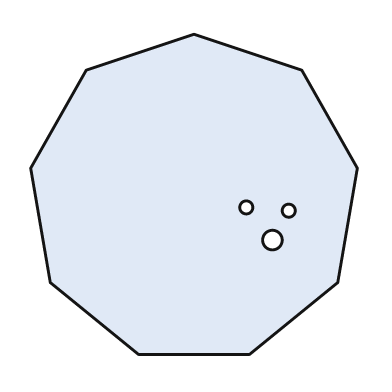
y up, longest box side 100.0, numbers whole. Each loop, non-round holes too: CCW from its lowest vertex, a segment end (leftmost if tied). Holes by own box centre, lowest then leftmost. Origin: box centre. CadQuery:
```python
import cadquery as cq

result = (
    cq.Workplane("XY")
    .moveTo(-17.0, -49.0)
    .lineTo(17.0, -49.0)
    .lineTo(44.0, -27.0)
    .lineTo(50.0, 8.0)
    .lineTo(33.0, 38.0)
    .lineTo(0.0, 49.0)
    .lineTo(-33.0, 38.0)
    .lineTo(-50.0, 8.0)
    .lineTo(-44.0, -27.0)
    .close()
    .moveTo(24.0, -14.0)
    .circle(3.0)
    .moveTo(29.0, -5.0)
    .circle(2.0)
    .moveTo(16.0, -4.0)
    .circle(2.0)
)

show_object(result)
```